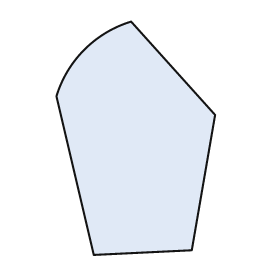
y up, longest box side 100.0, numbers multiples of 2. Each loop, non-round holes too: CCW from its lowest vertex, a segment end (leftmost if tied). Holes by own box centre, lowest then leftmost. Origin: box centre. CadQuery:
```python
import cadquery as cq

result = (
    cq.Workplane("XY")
    .moveTo(-18.0, -50.0)
    .lineTo(24.0, -48.0)
    .lineTo(34.0, 10.0)
    .lineTo(-2.0, 50.0)
    .threePointArc((-22.0, 38.0), (-34.0, 18.0))
    .close()
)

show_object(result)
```